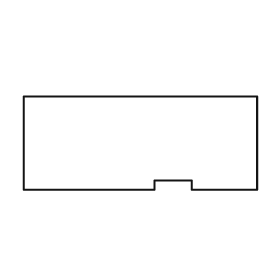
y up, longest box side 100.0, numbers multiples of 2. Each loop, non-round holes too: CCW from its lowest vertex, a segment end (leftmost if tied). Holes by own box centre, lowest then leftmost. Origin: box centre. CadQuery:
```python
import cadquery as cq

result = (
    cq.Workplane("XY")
    .moveTo(-50.0, -20.0)
    .lineTo(6.0, -20.0)
    .lineTo(6.0, -16.0)
    .lineTo(22.0, -16.0)
    .lineTo(22.0, -20.0)
    .lineTo(50.0, -20.0)
    .lineTo(50.0, 20.0)
    .lineTo(-50.0, 20.0)
    .close()
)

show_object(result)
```